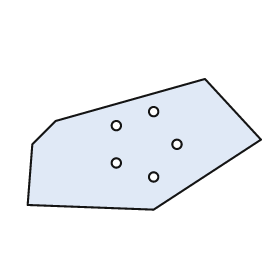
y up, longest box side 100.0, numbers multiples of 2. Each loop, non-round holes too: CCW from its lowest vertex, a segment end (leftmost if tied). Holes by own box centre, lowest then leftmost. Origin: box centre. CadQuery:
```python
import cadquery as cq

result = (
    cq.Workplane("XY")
    .moveTo(4.0, -28.0)
    .lineTo(50.0, 2.0)
    .lineTo(26.0, 28.0)
    .lineTo(-38.0, 10.0)
    .lineTo(-48.0, 0.0)
    .lineTo(-50.0, -26.0)
    .close()
    .moveTo(4.0, -14.0)
    .circle(2.0)
    .moveTo(-12.0, -8.0)
    .circle(2.0)
    .moveTo(14.0, 0.0)
    .circle(2.0)
    .moveTo(-12.0, 8.0)
    .circle(2.0)
    .moveTo(4.0, 14.0)
    .circle(2.0)
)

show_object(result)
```